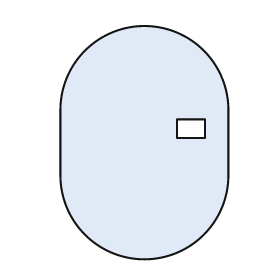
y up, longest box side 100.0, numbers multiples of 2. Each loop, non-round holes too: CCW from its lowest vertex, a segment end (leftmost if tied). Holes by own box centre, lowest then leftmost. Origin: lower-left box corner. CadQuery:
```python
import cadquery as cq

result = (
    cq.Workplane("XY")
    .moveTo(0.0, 36.0)
    .threePointArc((36.0, 0.0), (72.0, 36.0))
    .lineTo(72.0, 64.0)
    .threePointArc((36.0, 100.0), (0.0, 64.0))
    .close()
    .moveTo(50.0, 52.0)
    .lineTo(62.0, 52.0)
    .lineTo(62.0, 60.0)
    .lineTo(50.0, 60.0)
    .close()
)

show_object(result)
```